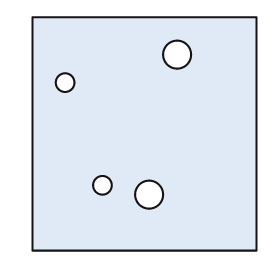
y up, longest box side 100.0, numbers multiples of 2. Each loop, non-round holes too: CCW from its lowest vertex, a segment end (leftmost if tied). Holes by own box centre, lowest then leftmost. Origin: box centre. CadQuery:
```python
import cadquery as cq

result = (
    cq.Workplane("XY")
    .moveTo(-48.0, -50.0)
    .lineTo(48.0, -50.0)
    .lineTo(48.0, 50.0)
    .lineTo(-48.0, 50.0)
    .close()
    .moveTo(2.0, -26.0)
    .circle(6.0)
    .moveTo(-18.0, -22.0)
    .circle(4.0)
    .moveTo(-34.0, 22.0)
    .circle(4.0)
    .moveTo(14.0, 34.0)
    .circle(6.0)
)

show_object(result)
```